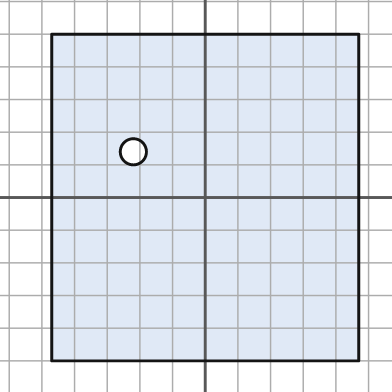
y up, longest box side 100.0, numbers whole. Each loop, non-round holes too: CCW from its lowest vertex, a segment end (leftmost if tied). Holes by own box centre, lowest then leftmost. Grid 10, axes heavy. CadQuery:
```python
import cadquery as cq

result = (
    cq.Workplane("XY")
    .moveTo(-47.0, -50.0)
    .lineTo(47.0, -50.0)
    .lineTo(47.0, 50.0)
    .lineTo(-47.0, 50.0)
    .close()
    .moveTo(-22.0, 14.0)
    .circle(4.0)
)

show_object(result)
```